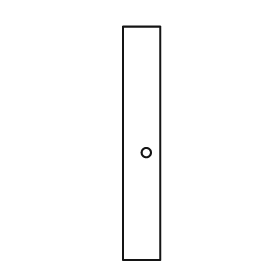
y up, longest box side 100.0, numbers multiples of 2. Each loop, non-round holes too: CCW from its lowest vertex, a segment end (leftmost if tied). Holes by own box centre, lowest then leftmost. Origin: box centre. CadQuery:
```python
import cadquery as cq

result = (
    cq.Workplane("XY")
    .moveTo(-8.0, -50.0)
    .lineTo(8.0, -50.0)
    .lineTo(8.0, 50.0)
    .lineTo(-8.0, 50.0)
    .close()
    .moveTo(2.0, -4.0)
    .circle(2.0)
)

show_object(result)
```